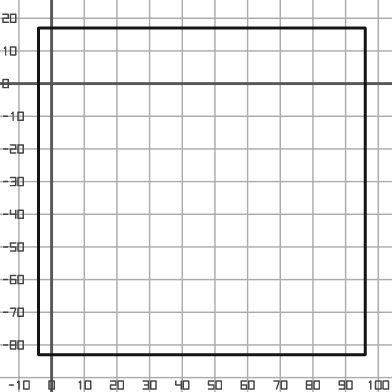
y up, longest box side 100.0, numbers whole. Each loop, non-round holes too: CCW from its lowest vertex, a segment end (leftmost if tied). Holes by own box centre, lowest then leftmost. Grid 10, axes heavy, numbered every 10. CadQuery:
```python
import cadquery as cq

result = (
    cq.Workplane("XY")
    .moveTo(-4.0, -83.0)
    .lineTo(96.0, -83.0)
    .lineTo(96.0, 17.0)
    .lineTo(-4.0, 17.0)
    .close()
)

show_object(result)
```